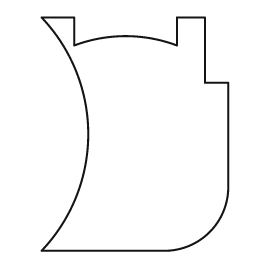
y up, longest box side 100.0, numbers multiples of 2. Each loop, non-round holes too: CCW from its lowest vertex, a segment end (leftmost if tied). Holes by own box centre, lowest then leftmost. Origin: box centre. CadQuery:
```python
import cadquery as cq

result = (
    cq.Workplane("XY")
    .moveTo(-40.0, -50.0)
    .lineTo(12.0, -50.0)
    .threePointArc((32.0, -42.0), (40.0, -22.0))
    .lineTo(40.0, 22.0)
    .lineTo(30.0, 22.0)
    .lineTo(30.0, 50.0)
    .lineTo(18.0, 50.0)
    .lineTo(18.0, 38.0)
    .threePointArc((-4.0, 42.0), (-26.0, 38.0))
    .lineTo(-26.0, 50.0)
    .lineTo(-40.0, 50.0)
    .threePointArc((-20.0, 0.0), (-40.0, -50.0))
    .close()
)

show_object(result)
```